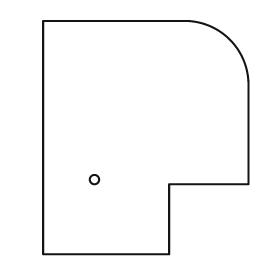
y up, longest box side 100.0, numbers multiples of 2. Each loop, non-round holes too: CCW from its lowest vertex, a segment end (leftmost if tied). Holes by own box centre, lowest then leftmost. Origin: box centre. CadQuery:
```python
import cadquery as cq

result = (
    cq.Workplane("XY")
    .moveTo(-44.0, -50.0)
    .lineTo(10.0, -50.0)
    .lineTo(10.0, -20.0)
    .lineTo(44.0, -20.0)
    .lineTo(44.0, 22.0)
    .threePointArc((36.0, 42.0), (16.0, 50.0))
    .lineTo(-44.0, 50.0)
    .close()
    .moveTo(-22.0, -18.0)
    .circle(2.0)
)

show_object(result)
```